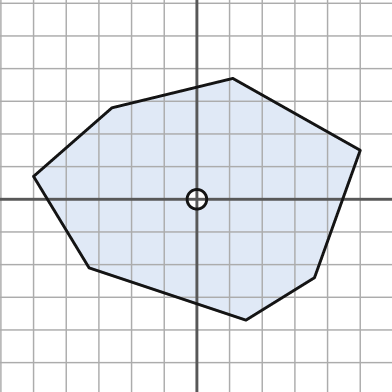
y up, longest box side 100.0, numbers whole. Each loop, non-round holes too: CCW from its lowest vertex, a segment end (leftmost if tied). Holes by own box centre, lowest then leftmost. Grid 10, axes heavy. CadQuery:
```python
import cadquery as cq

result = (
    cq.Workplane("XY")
    .moveTo(15.0, -37.0)
    .lineTo(36.0, -24.0)
    .lineTo(50.0, 15.0)
    .lineTo(11.0, 37.0)
    .lineTo(-26.0, 28.0)
    .lineTo(-50.0, 7.0)
    .lineTo(-33.0, -21.0)
    .close()
    .moveTo(0.0, 0.0)
    .circle(3.0)
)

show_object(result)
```